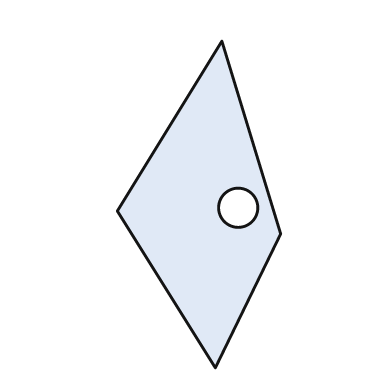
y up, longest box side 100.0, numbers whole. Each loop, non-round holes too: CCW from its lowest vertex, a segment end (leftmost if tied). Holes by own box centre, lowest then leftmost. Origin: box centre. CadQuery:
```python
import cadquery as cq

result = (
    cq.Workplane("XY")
    .moveTo(5.0, -50.0)
    .lineTo(25.0, -9.0)
    .lineTo(7.0, 50.0)
    .lineTo(-25.0, -2.0)
    .close()
    .moveTo(12.0, -1.0)
    .circle(6.0)
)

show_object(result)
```